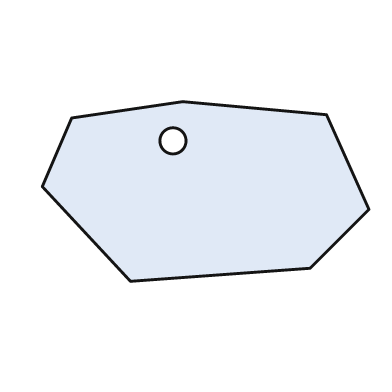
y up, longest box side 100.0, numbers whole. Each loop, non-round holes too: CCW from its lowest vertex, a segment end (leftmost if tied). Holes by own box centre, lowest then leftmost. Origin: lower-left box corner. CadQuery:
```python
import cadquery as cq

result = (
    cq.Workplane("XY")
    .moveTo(27.0, 0.0)
    .lineTo(82.0, 4.0)
    .lineTo(100.0, 22.0)
    .lineTo(87.0, 51.0)
    .lineTo(43.0, 55.0)
    .lineTo(9.0, 50.0)
    .lineTo(0.0, 29.0)
    .close()
    .moveTo(40.0, 43.0)
    .circle(4.0)
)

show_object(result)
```